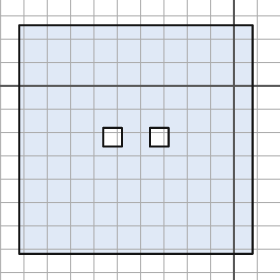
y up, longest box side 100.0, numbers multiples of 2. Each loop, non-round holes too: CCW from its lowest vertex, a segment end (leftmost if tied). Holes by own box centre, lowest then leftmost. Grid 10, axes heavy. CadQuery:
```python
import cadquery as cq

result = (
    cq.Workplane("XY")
    .moveTo(-92.0, -72.0)
    .lineTo(8.0, -72.0)
    .lineTo(8.0, 26.0)
    .lineTo(-92.0, 26.0)
    .close()
    .moveTo(-56.0, -26.0)
    .lineTo(-48.0, -26.0)
    .lineTo(-48.0, -18.0)
    .lineTo(-56.0, -18.0)
    .close()
    .moveTo(-36.0, -26.0)
    .lineTo(-28.0, -26.0)
    .lineTo(-28.0, -18.0)
    .lineTo(-36.0, -18.0)
    .close()
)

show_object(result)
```